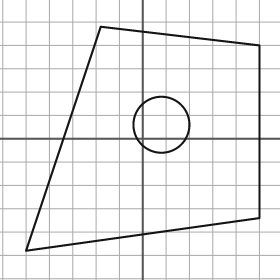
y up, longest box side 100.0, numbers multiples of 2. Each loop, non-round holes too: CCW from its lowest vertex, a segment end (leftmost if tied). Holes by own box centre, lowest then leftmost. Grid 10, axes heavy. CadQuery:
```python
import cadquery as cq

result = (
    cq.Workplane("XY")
    .moveTo(-50.0, -48.0)
    .lineTo(50.0, -34.0)
    .lineTo(50.0, 40.0)
    .lineTo(-18.0, 48.0)
    .close()
    .moveTo(8.0, 6.0)
    .circle(12.0)
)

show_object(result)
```